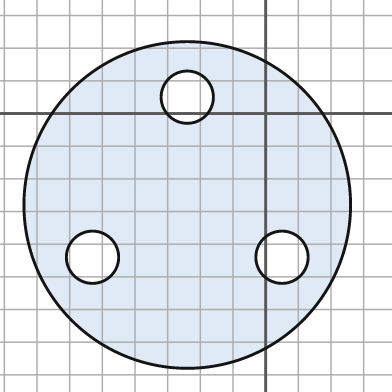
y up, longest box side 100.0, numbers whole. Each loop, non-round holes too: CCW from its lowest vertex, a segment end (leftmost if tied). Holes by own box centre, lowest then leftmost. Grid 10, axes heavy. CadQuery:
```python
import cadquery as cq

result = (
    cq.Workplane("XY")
    .moveTo(-24.0, -28.0)
    .circle(50.0)
    .moveTo(-53.0, -44.0)
    .circle(8.0)
    .moveTo(5.0, -44.0)
    .circle(8.0)
    .moveTo(-24.0, 5.0)
    .circle(8.0)
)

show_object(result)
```